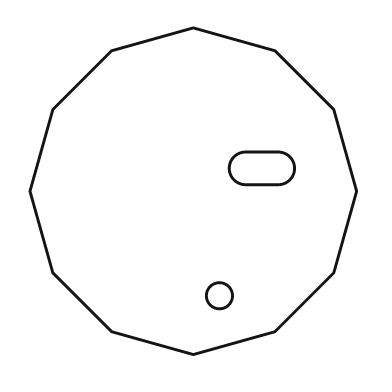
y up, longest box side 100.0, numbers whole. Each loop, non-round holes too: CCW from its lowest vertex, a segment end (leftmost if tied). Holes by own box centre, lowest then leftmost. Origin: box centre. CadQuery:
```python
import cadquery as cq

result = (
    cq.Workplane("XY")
    .moveTo(0.0, -50.0)
    .lineTo(25.0, -43.0)
    .lineTo(43.0, -25.0)
    .lineTo(50.0, 0.0)
    .lineTo(43.0, 25.0)
    .lineTo(25.0, 43.0)
    .lineTo(0.0, 50.0)
    .lineTo(-25.0, 43.0)
    .lineTo(-43.0, 25.0)
    .lineTo(-50.0, 0.0)
    .lineTo(-43.0, -25.0)
    .lineTo(-25.0, -43.0)
    .close()
    .moveTo(8.0, -32.0)
    .circle(4.0)
    .moveTo(16.0, 2.0)
    .lineTo(26.0, 2.0)
    .threePointArc((31.0, 7.0), (26.0, 12.0))
    .lineTo(16.0, 12.0)
    .threePointArc((11.0, 7.0), (16.0, 2.0))
    .close()
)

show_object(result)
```